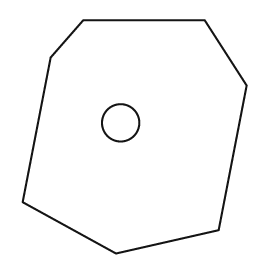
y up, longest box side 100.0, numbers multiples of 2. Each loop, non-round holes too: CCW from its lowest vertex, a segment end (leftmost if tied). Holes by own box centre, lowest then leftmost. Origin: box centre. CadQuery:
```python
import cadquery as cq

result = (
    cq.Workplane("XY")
    .moveTo(-8.0, -50.0)
    .lineTo(36.0, -40.0)
    .lineTo(48.0, 22.0)
    .lineTo(30.0, 50.0)
    .lineTo(-22.0, 50.0)
    .lineTo(-36.0, 34.0)
    .lineTo(-48.0, -28.0)
    .close()
    .moveTo(-6.0, 6.0)
    .circle(8.0)
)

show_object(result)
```